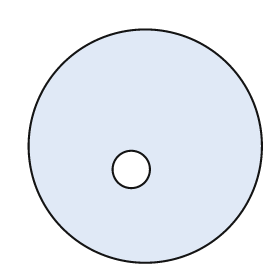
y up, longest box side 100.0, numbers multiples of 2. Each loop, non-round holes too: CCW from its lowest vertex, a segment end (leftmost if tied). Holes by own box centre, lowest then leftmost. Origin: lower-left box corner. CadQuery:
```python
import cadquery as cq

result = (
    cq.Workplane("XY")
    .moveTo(50.0, 50.0)
    .circle(50.0)
    .moveTo(44.0, 40.0)
    .circle(8.0)
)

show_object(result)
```